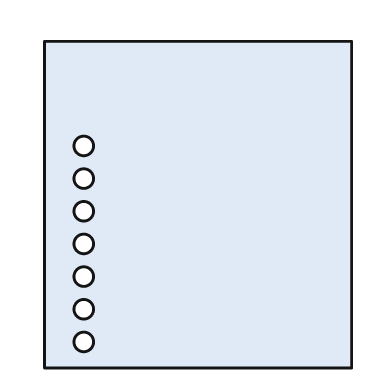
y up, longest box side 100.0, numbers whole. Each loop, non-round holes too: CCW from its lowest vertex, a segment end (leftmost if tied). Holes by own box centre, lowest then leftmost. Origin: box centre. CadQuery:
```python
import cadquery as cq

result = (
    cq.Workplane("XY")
    .moveTo(-47.0, -50.0)
    .lineTo(47.0, -50.0)
    .lineTo(47.0, 50.0)
    .lineTo(-47.0, 50.0)
    .close()
    .moveTo(-35.0, -42.0)
    .circle(3.0)
    .moveTo(-35.0, -32.0)
    .circle(3.0)
    .moveTo(-35.0, -22.0)
    .circle(3.0)
    .moveTo(-35.0, -12.0)
    .circle(3.0)
    .moveTo(-35.0, -2.0)
    .circle(3.0)
    .moveTo(-35.0, 8.0)
    .circle(3.0)
    .moveTo(-35.0, 18.0)
    .circle(3.0)
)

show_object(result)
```